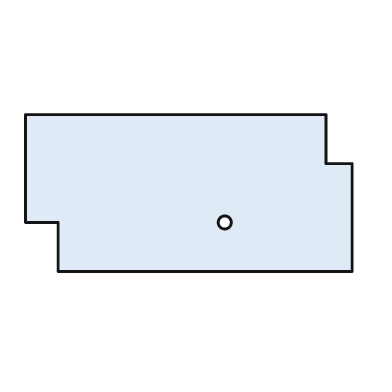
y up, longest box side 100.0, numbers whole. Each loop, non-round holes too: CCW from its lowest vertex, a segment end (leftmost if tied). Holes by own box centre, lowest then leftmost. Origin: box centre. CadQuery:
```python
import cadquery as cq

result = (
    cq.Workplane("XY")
    .moveTo(-40.0, -24.0)
    .lineTo(50.0, -24.0)
    .lineTo(50.0, 9.0)
    .lineTo(42.0, 9.0)
    .lineTo(42.0, 24.0)
    .lineTo(-50.0, 24.0)
    .lineTo(-50.0, -9.0)
    .lineTo(-40.0, -9.0)
    .close()
    .moveTo(11.0, -9.0)
    .circle(2.0)
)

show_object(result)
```